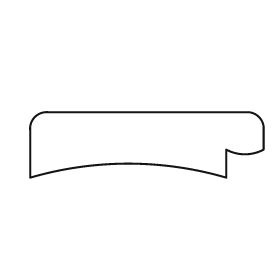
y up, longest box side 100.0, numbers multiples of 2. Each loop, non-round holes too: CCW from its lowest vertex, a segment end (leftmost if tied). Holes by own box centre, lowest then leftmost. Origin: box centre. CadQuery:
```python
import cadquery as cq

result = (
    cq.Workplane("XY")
    .moveTo(-50.0, -14.0)
    .threePointArc((-8.0, -8.0), (34.0, -14.0))
    .lineTo(34.0, -2.0)
    .threePointArc((42.0, -4.0), (50.0, -2.0))
    .lineTo(50.0, 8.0)
    .threePointArc((48.0, 12.0), (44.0, 14.0))
    .lineTo(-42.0, 14.0)
    .threePointArc((-48.0, 12.0), (-50.0, 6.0))
    .close()
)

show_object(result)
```